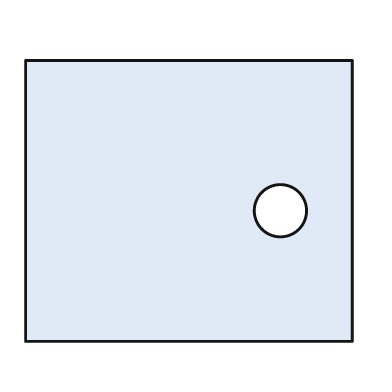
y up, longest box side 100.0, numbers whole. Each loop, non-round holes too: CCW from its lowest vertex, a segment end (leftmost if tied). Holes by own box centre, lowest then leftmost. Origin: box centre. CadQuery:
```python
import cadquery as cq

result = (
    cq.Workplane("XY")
    .moveTo(-50.0, -43.0)
    .lineTo(50.0, -43.0)
    .lineTo(50.0, 43.0)
    .lineTo(-50.0, 43.0)
    .close()
    .moveTo(28.0, -3.0)
    .circle(8.0)
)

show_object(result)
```